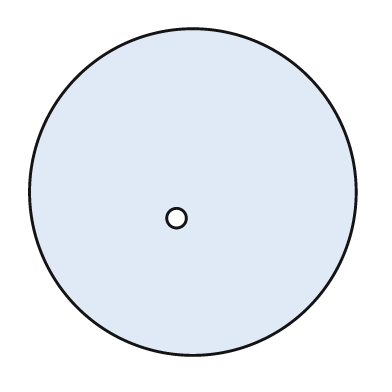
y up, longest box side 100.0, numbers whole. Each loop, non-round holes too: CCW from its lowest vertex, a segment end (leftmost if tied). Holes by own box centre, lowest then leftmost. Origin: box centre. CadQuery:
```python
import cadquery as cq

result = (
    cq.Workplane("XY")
    .moveTo(0.0, 0.0)
    .circle(50.0)
    .moveTo(-5.0, -8.0)
    .circle(3.0)
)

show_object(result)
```